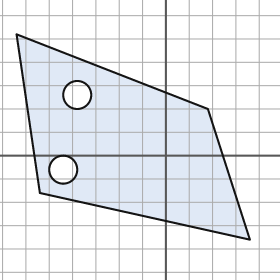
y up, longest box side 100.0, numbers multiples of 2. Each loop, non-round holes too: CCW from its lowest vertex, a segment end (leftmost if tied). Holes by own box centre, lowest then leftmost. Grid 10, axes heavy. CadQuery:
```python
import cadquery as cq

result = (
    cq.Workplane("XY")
    .moveTo(36.0, -36.0)
    .lineTo(18.0, 20.0)
    .lineTo(-64.0, 52.0)
    .lineTo(-54.0, -16.0)
    .close()
    .moveTo(-44.0, -6.0)
    .circle(6.0)
    .moveTo(-38.0, 26.0)
    .circle(6.0)
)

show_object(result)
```